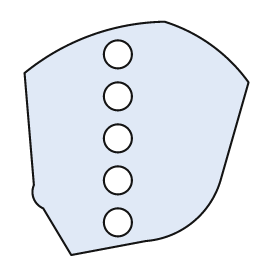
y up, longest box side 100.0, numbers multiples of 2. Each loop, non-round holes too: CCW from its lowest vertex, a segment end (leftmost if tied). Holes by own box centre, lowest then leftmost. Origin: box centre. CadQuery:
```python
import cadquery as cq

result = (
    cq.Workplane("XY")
    .moveTo(-28.0, -50.0)
    .lineTo(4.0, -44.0)
    .threePointArc((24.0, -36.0), (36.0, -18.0))
    .lineTo(48.0, 24.0)
    .threePointArc((32.0, 40.0), (12.0, 50.0))
    .threePointArc((-20.0, 44.0), (-48.0, 28.0))
    .lineTo(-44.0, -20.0)
    .threePointArc((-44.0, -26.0), (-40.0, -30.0))
    .close()
    .moveTo(-8.0, -36.0)
    .circle(6.0)
    .moveTo(-8.0, -18.0)
    .circle(6.0)
    .moveTo(-8.0, 0.0)
    .circle(6.0)
    .moveTo(-8.0, 18.0)
    .circle(6.0)
    .moveTo(-8.0, 36.0)
    .circle(6.0)
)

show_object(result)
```